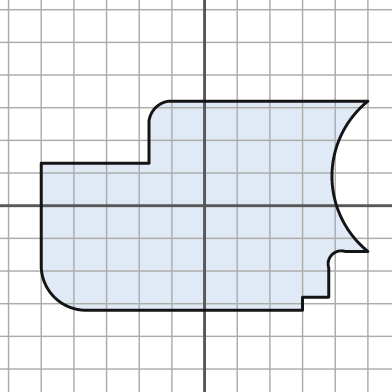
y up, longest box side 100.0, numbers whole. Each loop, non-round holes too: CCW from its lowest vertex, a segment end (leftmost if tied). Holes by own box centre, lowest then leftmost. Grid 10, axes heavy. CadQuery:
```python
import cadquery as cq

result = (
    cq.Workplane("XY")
    .moveTo(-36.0, -32.0)
    .lineTo(30.0, -32.0)
    .lineTo(30.0, -28.0)
    .lineTo(38.0, -28.0)
    .lineTo(38.0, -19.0)
    .threePointArc((39.0, -15.0), (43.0, -14.0))
    .lineTo(50.0, -14.0)
    .threePointArc((39.0, 9.0), (50.0, 32.0))
    .lineTo(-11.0, 32.0)
    .threePointArc((-15.0, 30.0), (-17.0, 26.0))
    .lineTo(-17.0, 13.0)
    .lineTo(-50.0, 13.0)
    .lineTo(-50.0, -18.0)
    .threePointArc((-46.0, -28.0), (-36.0, -32.0))
    .close()
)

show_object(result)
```